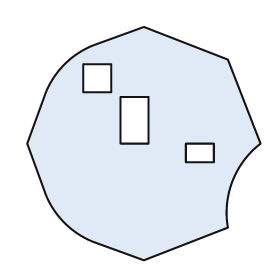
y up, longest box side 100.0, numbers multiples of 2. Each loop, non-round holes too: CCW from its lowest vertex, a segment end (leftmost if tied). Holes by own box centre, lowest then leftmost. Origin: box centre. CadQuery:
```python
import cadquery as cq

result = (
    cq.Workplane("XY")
    .moveTo(0.0, -50.0)
    .lineTo(36.0, -36.0)
    .threePointArc((38.0, -16.0), (50.0, 0.0))
    .lineTo(36.0, 36.0)
    .lineTo(0.0, 50.0)
    .lineTo(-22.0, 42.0)
    .threePointArc((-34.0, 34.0), (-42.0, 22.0))
    .lineTo(-50.0, 0.0)
    .lineTo(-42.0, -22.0)
    .threePointArc((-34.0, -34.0), (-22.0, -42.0))
    .close()
    .moveTo(18.0, -8.0)
    .lineTo(30.0, -8.0)
    .lineTo(30.0, 0.0)
    .lineTo(18.0, 0.0)
    .close()
    .moveTo(-10.0, 0.0)
    .lineTo(2.0, 0.0)
    .lineTo(2.0, 20.0)
    .lineTo(-10.0, 20.0)
    .close()
    .moveTo(-26.0, 22.0)
    .lineTo(-14.0, 22.0)
    .lineTo(-14.0, 34.0)
    .lineTo(-26.0, 34.0)
    .close()
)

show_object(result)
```